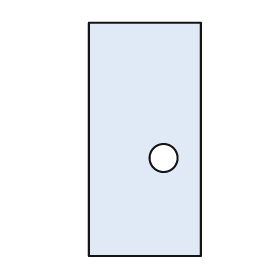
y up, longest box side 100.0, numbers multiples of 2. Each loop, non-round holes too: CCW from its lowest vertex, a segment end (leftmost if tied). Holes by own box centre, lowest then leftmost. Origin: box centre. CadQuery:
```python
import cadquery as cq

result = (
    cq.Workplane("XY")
    .moveTo(-24.0, -50.0)
    .lineTo(24.0, -50.0)
    .lineTo(24.0, 50.0)
    .lineTo(-24.0, 50.0)
    .close()
    .moveTo(8.0, -8.0)
    .circle(6.0)
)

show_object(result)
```